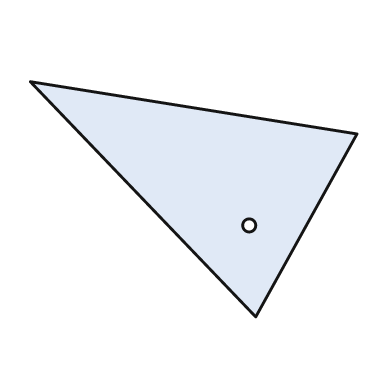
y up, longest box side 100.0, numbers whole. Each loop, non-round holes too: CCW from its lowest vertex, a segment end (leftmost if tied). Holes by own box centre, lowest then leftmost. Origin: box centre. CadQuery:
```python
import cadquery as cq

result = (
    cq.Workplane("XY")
    .moveTo(19.0, -36.0)
    .lineTo(50.0, 20.0)
    .lineTo(-50.0, 36.0)
    .close()
    .moveTo(17.0, -8.0)
    .circle(2.0)
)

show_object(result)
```